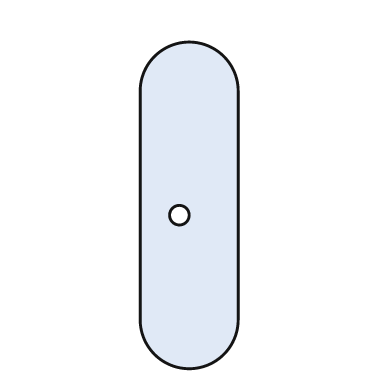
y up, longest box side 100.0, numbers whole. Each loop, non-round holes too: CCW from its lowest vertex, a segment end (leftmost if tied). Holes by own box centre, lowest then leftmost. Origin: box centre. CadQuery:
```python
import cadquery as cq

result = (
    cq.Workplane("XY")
    .moveTo(-15.0, -35.0)
    .threePointArc((0.0, -50.0), (15.0, -35.0))
    .lineTo(15.0, 35.0)
    .threePointArc((0.0, 50.0), (-15.0, 35.0))
    .close()
    .moveTo(-3.0, -3.0)
    .circle(3.0)
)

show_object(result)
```